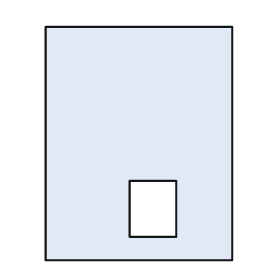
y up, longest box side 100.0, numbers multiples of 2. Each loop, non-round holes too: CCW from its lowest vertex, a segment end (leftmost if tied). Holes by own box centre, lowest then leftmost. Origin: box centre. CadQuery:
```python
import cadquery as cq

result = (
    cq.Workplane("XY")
    .moveTo(-40.0, -50.0)
    .lineTo(40.0, -50.0)
    .lineTo(40.0, 50.0)
    .lineTo(-40.0, 50.0)
    .close()
    .moveTo(-4.0, -40.0)
    .lineTo(16.0, -40.0)
    .lineTo(16.0, -16.0)
    .lineTo(-4.0, -16.0)
    .close()
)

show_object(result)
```